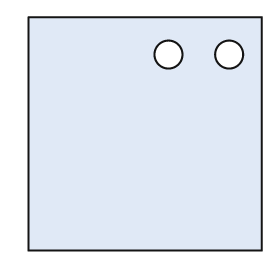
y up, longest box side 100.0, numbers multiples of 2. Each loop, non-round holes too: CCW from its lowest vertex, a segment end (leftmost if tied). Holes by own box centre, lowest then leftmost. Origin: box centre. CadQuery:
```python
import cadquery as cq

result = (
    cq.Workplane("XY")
    .moveTo(-50.0, -50.0)
    .lineTo(50.0, -50.0)
    .lineTo(50.0, 50.0)
    .lineTo(-50.0, 50.0)
    .close()
    .moveTo(10.0, 34.0)
    .circle(6.0)
    .moveTo(36.0, 34.0)
    .circle(6.0)
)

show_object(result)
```